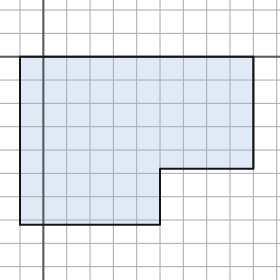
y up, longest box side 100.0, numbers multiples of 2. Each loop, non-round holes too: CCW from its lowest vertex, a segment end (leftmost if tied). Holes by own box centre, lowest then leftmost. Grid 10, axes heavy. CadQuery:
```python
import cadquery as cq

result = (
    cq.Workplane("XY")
    .moveTo(-10.0, -72.0)
    .lineTo(50.0, -72.0)
    .lineTo(50.0, -48.0)
    .lineTo(90.0, -48.0)
    .lineTo(90.0, 0.0)
    .lineTo(-10.0, 0.0)
    .close()
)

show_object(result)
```